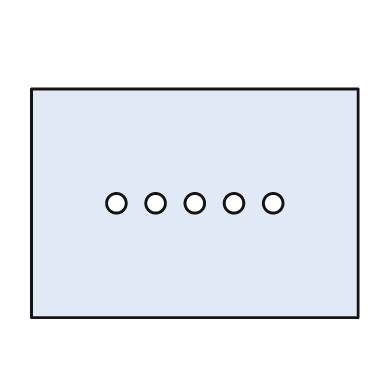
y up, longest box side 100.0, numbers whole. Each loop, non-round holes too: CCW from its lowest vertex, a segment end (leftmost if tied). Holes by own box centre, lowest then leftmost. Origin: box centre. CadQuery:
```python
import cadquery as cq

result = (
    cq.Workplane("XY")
    .moveTo(-50.0, -35.0)
    .lineTo(50.0, -35.0)
    .lineTo(50.0, 35.0)
    .lineTo(-50.0, 35.0)
    .close()
    .moveTo(-24.0, 0.0)
    .circle(3.0)
    .moveTo(-12.0, 0.0)
    .circle(3.0)
    .moveTo(0.0, 0.0)
    .circle(3.0)
    .moveTo(12.0, 0.0)
    .circle(3.0)
    .moveTo(24.0, 0.0)
    .circle(3.0)
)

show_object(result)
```